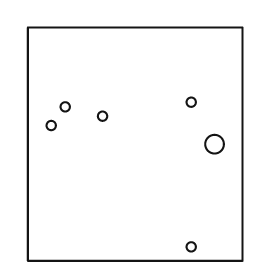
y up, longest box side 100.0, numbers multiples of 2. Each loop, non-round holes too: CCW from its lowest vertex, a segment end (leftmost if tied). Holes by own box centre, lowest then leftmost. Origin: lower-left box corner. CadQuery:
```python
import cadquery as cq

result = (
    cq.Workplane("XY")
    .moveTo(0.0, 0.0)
    .lineTo(92.0, 0.0)
    .lineTo(92.0, 100.0)
    .lineTo(0.0, 100.0)
    .close()
    .moveTo(70.0, 6.0)
    .circle(2.0)
    .moveTo(80.0, 50.0)
    .circle(4.0)
    .moveTo(10.0, 58.0)
    .circle(2.0)
    .moveTo(32.0, 62.0)
    .circle(2.0)
    .moveTo(16.0, 66.0)
    .circle(2.0)
    .moveTo(70.0, 68.0)
    .circle(2.0)
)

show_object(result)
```